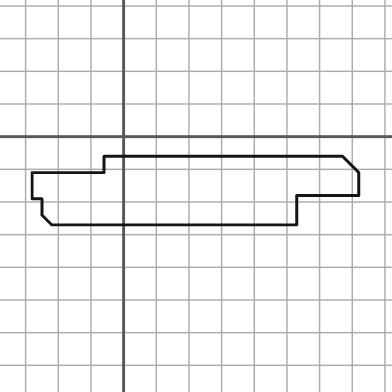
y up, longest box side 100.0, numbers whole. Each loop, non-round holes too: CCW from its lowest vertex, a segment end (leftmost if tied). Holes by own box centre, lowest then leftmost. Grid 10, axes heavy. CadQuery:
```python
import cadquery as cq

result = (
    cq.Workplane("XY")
    .moveTo(-22.0, -27.0)
    .lineTo(53.0, -27.0)
    .lineTo(53.0, -18.0)
    .lineTo(72.0, -18.0)
    .lineTo(72.0, -11.0)
    .lineTo(67.0, -6.0)
    .lineTo(-6.0, -6.0)
    .lineTo(-6.0, -11.0)
    .lineTo(-28.0, -11.0)
    .lineTo(-28.0, -19.0)
    .lineTo(-25.0, -19.0)
    .lineTo(-25.0, -24.0)
    .close()
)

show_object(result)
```